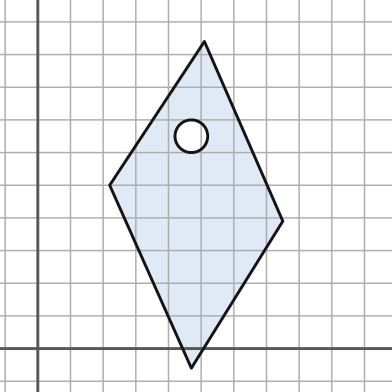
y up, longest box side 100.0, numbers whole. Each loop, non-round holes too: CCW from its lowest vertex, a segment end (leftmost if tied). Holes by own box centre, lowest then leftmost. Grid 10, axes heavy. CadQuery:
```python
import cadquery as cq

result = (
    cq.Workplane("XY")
    .moveTo(47.0, -6.0)
    .lineTo(75.0, 39.0)
    .lineTo(51.0, 94.0)
    .lineTo(22.0, 50.0)
    .close()
    .moveTo(47.0, 65.0)
    .circle(5.0)
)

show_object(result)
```